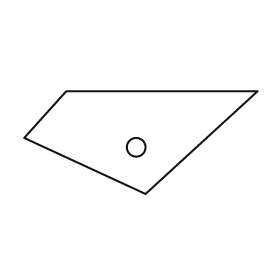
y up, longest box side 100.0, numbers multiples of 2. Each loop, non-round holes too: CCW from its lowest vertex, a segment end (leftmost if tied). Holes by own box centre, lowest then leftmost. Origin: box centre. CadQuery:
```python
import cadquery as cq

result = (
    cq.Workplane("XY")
    .moveTo(2.0, -22.0)
    .lineTo(50.0, 22.0)
    .lineTo(-32.0, 22.0)
    .lineTo(-50.0, 2.0)
    .close()
    .moveTo(-2.0, -2.0)
    .circle(4.0)
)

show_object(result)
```